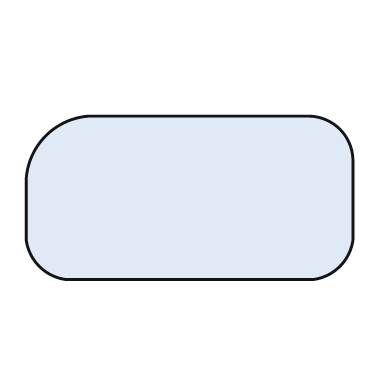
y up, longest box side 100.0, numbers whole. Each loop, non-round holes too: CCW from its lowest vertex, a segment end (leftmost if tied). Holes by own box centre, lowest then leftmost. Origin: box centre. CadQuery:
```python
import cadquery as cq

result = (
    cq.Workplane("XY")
    .moveTo(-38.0, -25.0)
    .lineTo(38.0, -25.0)
    .threePointArc((46.0, -21.0), (50.0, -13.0))
    .lineTo(50.0, 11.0)
    .threePointArc((46.0, 21.0), (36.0, 25.0))
    .lineTo(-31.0, 25.0)
    .threePointArc((-44.0, 19.0), (-50.0, 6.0))
    .lineTo(-50.0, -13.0)
    .threePointArc((-46.0, -21.0), (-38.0, -25.0))
    .close()
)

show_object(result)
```